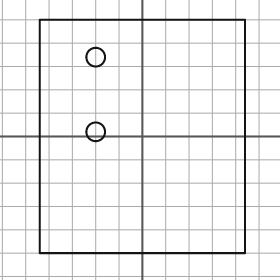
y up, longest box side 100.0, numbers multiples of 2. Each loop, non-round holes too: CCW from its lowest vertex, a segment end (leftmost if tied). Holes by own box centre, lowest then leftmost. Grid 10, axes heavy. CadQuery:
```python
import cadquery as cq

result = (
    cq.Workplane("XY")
    .moveTo(-44.0, -50.0)
    .lineTo(44.0, -50.0)
    .lineTo(44.0, 50.0)
    .lineTo(-44.0, 50.0)
    .close()
    .moveTo(-20.0, 2.0)
    .circle(4.0)
    .moveTo(-20.0, 34.0)
    .circle(4.0)
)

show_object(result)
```